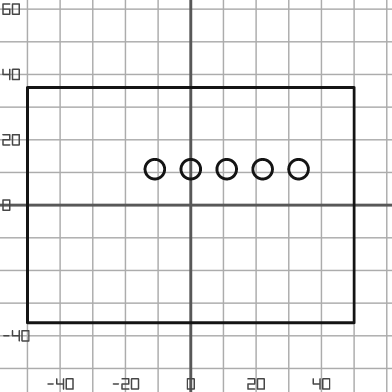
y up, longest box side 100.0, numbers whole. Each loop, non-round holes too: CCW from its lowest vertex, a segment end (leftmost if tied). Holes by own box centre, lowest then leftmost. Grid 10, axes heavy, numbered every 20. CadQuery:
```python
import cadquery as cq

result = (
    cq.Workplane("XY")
    .moveTo(-50.0, -36.0)
    .lineTo(50.0, -36.0)
    .lineTo(50.0, 36.0)
    .lineTo(-50.0, 36.0)
    .close()
    .moveTo(-11.0, 11.0)
    .circle(3.0)
    .moveTo(0.0, 11.0)
    .circle(3.0)
    .moveTo(11.0, 11.0)
    .circle(3.0)
    .moveTo(22.0, 11.0)
    .circle(3.0)
    .moveTo(33.0, 11.0)
    .circle(3.0)
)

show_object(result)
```